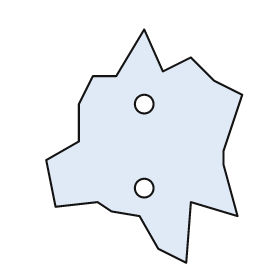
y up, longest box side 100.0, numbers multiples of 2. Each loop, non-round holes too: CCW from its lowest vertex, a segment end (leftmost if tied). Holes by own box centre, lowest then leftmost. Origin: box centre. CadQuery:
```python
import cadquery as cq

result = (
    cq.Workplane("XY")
    .moveTo(18.0, -50.0)
    .lineTo(20.0, -24.0)
    .lineTo(40.0, -30.0)
    .lineTo(34.0, -8.0)
    .lineTo(34.0, -2.0)
    .lineTo(42.0, 22.0)
    .lineTo(30.0, 28.0)
    .lineTo(20.0, 38.0)
    .lineTo(8.0, 32.0)
    .lineTo(0.0, 50.0)
    .lineTo(-12.0, 30.0)
    .lineTo(-22.0, 30.0)
    .lineTo(-28.0, 18.0)
    .lineTo(-28.0, 2.0)
    .lineTo(-42.0, -6.0)
    .lineTo(-38.0, -26.0)
    .lineTo(-20.0, -24.0)
    .lineTo(-14.0, -28.0)
    .lineTo(-2.0, -30.0)
    .lineTo(6.0, -44.0)
    .close()
    .moveTo(0.0, -18.0)
    .circle(4.0)
    .moveTo(0.0, 18.0)
    .circle(4.0)
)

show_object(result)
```